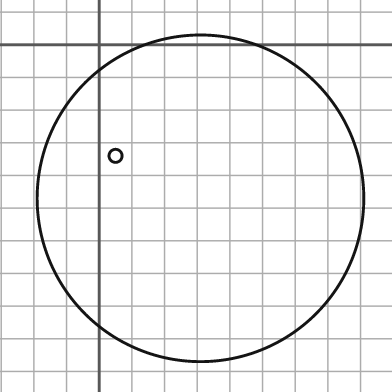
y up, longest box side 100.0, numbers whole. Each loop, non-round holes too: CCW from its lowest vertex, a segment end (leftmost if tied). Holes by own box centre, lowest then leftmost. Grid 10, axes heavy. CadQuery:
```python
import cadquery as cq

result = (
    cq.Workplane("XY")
    .moveTo(31.0, -47.0)
    .circle(50.0)
    .moveTo(5.0, -34.0)
    .circle(2.0)
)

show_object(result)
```